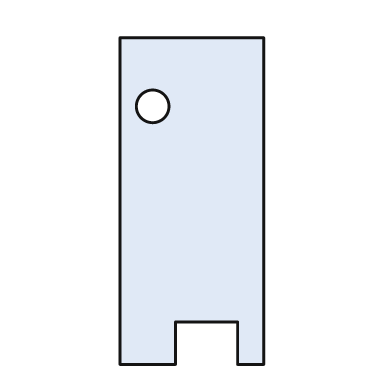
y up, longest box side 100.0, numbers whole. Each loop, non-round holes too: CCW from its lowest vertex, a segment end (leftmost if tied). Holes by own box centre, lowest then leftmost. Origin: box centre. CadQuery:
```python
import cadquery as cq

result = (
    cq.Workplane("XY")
    .moveTo(-22.0, -50.0)
    .lineTo(-5.0, -50.0)
    .lineTo(-5.0, -37.0)
    .lineTo(14.0, -37.0)
    .lineTo(14.0, -50.0)
    .lineTo(22.0, -50.0)
    .lineTo(22.0, 50.0)
    .lineTo(-22.0, 50.0)
    .close()
    .moveTo(-12.0, 29.0)
    .circle(5.0)
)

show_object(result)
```